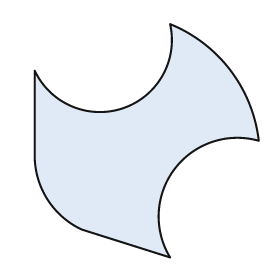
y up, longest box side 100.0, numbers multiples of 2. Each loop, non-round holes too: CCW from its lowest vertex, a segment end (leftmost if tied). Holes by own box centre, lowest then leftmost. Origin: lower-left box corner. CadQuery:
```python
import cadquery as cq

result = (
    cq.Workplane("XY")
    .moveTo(58.0, 0.0)
    .threePointArc((60.0, 38.0), (96.0, 50.0))
    .threePointArc((84.0, 80.0), (58.0, 100.0))
    .threePointArc((38.0, 64.0), (0.0, 80.0))
    .lineTo(0.0, 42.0)
    .threePointArc((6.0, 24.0), (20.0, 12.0))
    .close()
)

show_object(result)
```